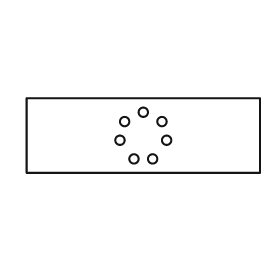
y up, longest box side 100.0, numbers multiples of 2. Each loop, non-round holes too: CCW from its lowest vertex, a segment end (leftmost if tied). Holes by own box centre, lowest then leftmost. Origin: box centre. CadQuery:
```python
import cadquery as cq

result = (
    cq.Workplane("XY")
    .moveTo(-50.0, -16.0)
    .lineTo(50.0, -16.0)
    .lineTo(50.0, 16.0)
    .lineTo(-50.0, 16.0)
    .close()
    .moveTo(-4.0, -10.0)
    .circle(2.0)
    .moveTo(4.0, -10.0)
    .circle(2.0)
    .moveTo(-10.0, -2.0)
    .circle(2.0)
    .moveTo(10.0, -2.0)
    .circle(2.0)
    .moveTo(-8.0, 6.0)
    .circle(2.0)
    .moveTo(8.0, 6.0)
    .circle(2.0)
    .moveTo(0.0, 10.0)
    .circle(2.0)
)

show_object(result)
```